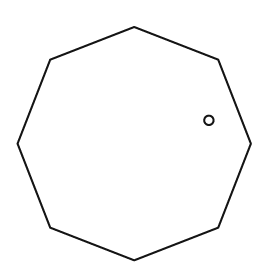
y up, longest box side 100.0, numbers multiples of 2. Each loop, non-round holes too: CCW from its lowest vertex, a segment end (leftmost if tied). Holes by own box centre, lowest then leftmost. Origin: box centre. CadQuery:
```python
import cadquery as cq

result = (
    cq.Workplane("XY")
    .moveTo(0.0, -50.0)
    .lineTo(36.0, -36.0)
    .lineTo(50.0, 0.0)
    .lineTo(36.0, 36.0)
    .lineTo(0.0, 50.0)
    .lineTo(-36.0, 36.0)
    .lineTo(-50.0, 0.0)
    .lineTo(-36.0, -36.0)
    .close()
    .moveTo(32.0, 10.0)
    .circle(2.0)
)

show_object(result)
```